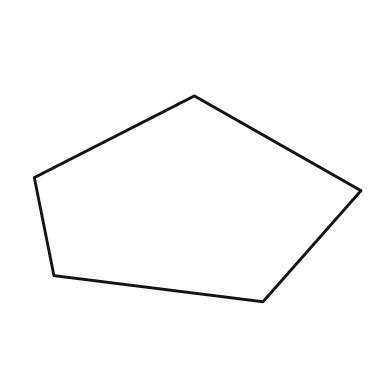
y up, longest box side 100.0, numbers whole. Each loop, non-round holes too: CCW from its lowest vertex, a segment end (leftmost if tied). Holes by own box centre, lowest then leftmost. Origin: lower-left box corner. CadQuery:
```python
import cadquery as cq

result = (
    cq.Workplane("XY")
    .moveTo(70.0, 0.0)
    .lineTo(100.0, 34.0)
    .lineTo(49.0, 63.0)
    .lineTo(0.0, 38.0)
    .lineTo(6.0, 8.0)
    .close()
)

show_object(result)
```